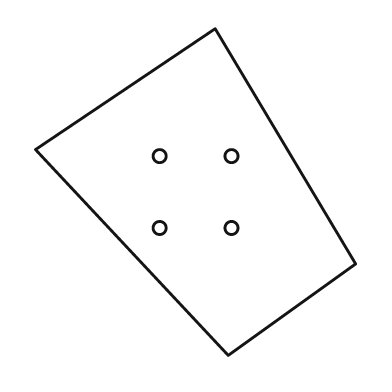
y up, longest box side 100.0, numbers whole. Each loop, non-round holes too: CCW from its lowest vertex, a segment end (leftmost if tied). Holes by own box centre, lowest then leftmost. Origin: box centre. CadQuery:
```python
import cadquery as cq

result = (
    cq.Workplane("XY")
    .moveTo(10.0, -50.0)
    .lineTo(49.0, -22.0)
    .lineTo(6.0, 50.0)
    .lineTo(-49.0, 13.0)
    .close()
    .moveTo(-11.0, -11.0)
    .circle(2.0)
    .moveTo(11.0, -11.0)
    .circle(2.0)
    .moveTo(-11.0, 11.0)
    .circle(2.0)
    .moveTo(11.0, 11.0)
    .circle(2.0)
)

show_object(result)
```